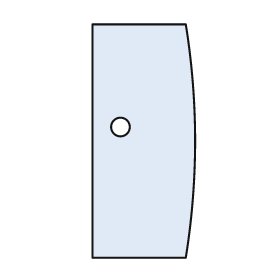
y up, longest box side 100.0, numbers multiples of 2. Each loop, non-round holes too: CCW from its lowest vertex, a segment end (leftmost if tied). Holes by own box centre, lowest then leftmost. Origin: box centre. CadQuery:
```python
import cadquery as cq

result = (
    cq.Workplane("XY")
    .moveTo(-22.0, -50.0)
    .lineTo(18.0, -50.0)
    .threePointArc((22.0, 0.0), (18.0, 50.0))
    .lineTo(-22.0, 50.0)
    .close()
    .moveTo(-10.0, 6.0)
    .circle(4.0)
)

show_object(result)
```